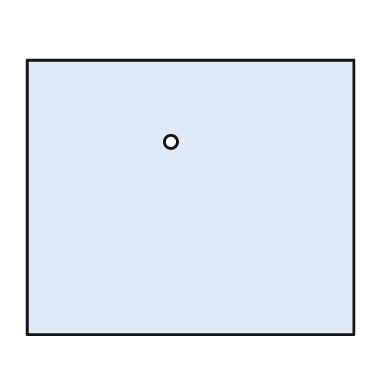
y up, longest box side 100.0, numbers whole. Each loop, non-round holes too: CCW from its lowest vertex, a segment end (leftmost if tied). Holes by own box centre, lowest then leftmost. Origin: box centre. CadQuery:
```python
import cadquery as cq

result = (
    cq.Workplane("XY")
    .moveTo(-50.0, -42.0)
    .lineTo(50.0, -42.0)
    .lineTo(50.0, 42.0)
    .lineTo(-50.0, 42.0)
    .close()
    .moveTo(-6.0, 17.0)
    .circle(2.0)
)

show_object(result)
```